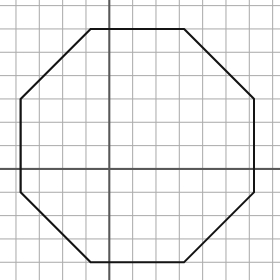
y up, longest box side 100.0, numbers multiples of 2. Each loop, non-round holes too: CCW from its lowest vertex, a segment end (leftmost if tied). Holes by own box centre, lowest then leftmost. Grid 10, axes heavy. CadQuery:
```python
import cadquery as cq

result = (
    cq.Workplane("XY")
    .moveTo(-8.0, -40.0)
    .lineTo(32.0, -40.0)
    .lineTo(62.0, -10.0)
    .lineTo(62.0, 30.0)
    .lineTo(32.0, 60.0)
    .lineTo(-8.0, 60.0)
    .lineTo(-38.0, 30.0)
    .lineTo(-38.0, -10.0)
    .close()
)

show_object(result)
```